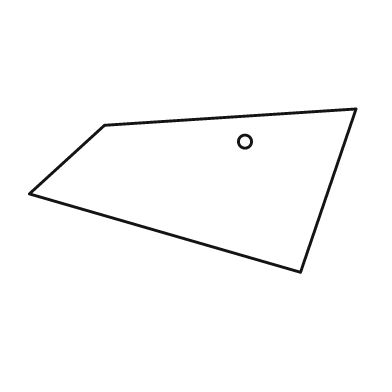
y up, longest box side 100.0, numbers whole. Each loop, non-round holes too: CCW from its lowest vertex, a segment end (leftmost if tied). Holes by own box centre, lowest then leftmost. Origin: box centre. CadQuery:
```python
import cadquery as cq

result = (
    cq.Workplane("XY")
    .moveTo(33.0, -25.0)
    .lineTo(50.0, 25.0)
    .lineTo(-27.0, 20.0)
    .lineTo(-50.0, -1.0)
    .close()
    .moveTo(16.0, 15.0)
    .circle(2.0)
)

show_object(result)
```